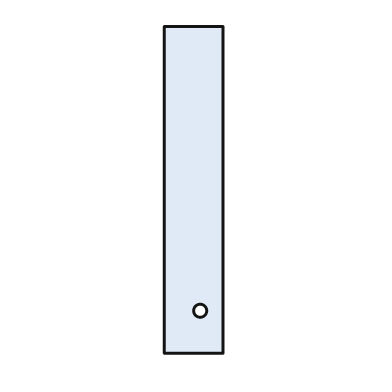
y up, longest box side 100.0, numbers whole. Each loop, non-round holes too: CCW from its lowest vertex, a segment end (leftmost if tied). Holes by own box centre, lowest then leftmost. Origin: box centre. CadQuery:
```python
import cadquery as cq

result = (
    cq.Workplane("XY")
    .moveTo(-9.0, -50.0)
    .lineTo(9.0, -50.0)
    .lineTo(9.0, 50.0)
    .lineTo(-9.0, 50.0)
    .close()
    .moveTo(2.0, -37.0)
    .circle(2.0)
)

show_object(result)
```